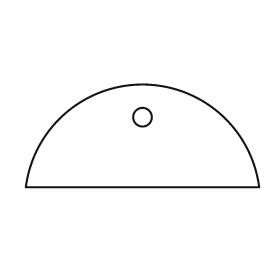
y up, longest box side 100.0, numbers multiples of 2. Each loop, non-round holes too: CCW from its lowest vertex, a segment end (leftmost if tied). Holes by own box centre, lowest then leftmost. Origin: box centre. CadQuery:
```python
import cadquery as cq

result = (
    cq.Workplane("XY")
    .moveTo(-50.0, -22.0)
    .lineTo(50.0, -22.0)
    .threePointArc((0.0, 22.0), (-50.0, -22.0))
    .close()
    .moveTo(0.0, 8.0)
    .circle(4.0)
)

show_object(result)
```